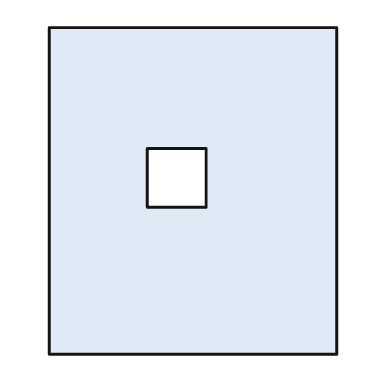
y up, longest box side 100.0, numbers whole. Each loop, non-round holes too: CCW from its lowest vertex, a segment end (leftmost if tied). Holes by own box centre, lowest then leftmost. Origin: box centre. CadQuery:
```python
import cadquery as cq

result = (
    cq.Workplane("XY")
    .moveTo(-44.0, -50.0)
    .lineTo(44.0, -50.0)
    .lineTo(44.0, 50.0)
    .lineTo(-44.0, 50.0)
    .close()
    .moveTo(-14.0, -5.0)
    .lineTo(4.0, -5.0)
    .lineTo(4.0, 13.0)
    .lineTo(-14.0, 13.0)
    .close()
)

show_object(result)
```